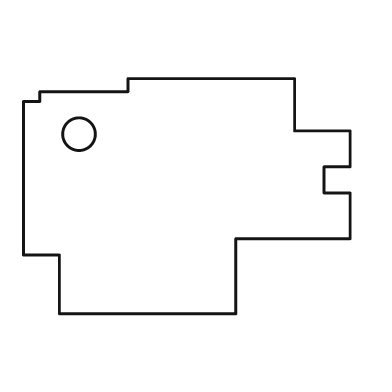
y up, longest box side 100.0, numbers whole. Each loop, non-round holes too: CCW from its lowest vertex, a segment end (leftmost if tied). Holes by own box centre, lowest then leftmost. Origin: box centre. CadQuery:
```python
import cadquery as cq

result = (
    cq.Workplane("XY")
    .moveTo(-39.0, -36.0)
    .lineTo(15.0, -36.0)
    .lineTo(15.0, -13.0)
    .lineTo(50.0, -13.0)
    .lineTo(50.0, 1.0)
    .lineTo(42.0, 1.0)
    .lineTo(42.0, 9.0)
    .lineTo(50.0, 9.0)
    .lineTo(50.0, 20.0)
    .lineTo(33.0, 20.0)
    .lineTo(33.0, 36.0)
    .lineTo(-18.0, 36.0)
    .lineTo(-18.0, 32.0)
    .lineTo(-45.0, 32.0)
    .lineTo(-45.0, 29.0)
    .lineTo(-50.0, 29.0)
    .lineTo(-50.0, -18.0)
    .lineTo(-39.0, -18.0)
    .close()
    .moveTo(-33.0, 19.0)
    .circle(5.0)
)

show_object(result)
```